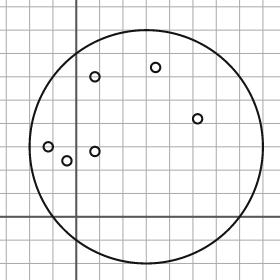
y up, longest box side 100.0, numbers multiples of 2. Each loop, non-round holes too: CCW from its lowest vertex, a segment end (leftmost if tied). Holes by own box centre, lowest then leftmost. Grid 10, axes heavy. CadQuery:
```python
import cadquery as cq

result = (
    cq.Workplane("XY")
    .moveTo(30.0, 30.0)
    .circle(50.0)
    .moveTo(-4.0, 24.0)
    .circle(2.0)
    .moveTo(8.0, 28.0)
    .circle(2.0)
    .moveTo(-12.0, 30.0)
    .circle(2.0)
    .moveTo(52.0, 42.0)
    .circle(2.0)
    .moveTo(8.0, 60.0)
    .circle(2.0)
    .moveTo(34.0, 64.0)
    .circle(2.0)
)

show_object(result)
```